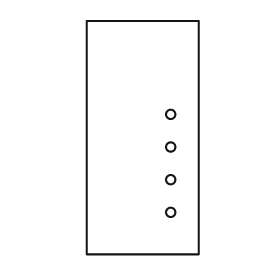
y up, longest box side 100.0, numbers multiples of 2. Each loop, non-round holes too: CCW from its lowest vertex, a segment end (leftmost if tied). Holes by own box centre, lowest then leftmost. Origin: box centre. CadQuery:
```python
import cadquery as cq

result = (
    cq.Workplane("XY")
    .moveTo(-24.0, -50.0)
    .lineTo(24.0, -50.0)
    .lineTo(24.0, 50.0)
    .lineTo(-24.0, 50.0)
    .close()
    .moveTo(12.0, -32.0)
    .circle(2.0)
    .moveTo(12.0, -18.0)
    .circle(2.0)
    .moveTo(12.0, -4.0)
    .circle(2.0)
    .moveTo(12.0, 10.0)
    .circle(2.0)
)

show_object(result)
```